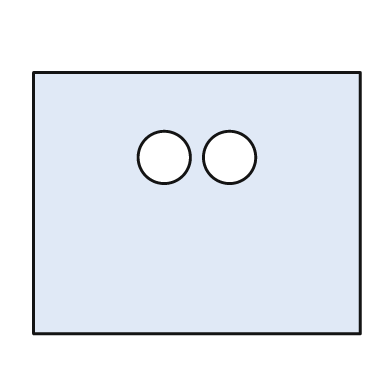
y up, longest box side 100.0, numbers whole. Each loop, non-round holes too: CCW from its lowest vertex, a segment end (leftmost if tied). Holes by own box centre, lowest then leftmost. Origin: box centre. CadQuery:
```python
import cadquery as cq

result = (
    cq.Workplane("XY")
    .moveTo(-50.0, -40.0)
    .lineTo(50.0, -40.0)
    .lineTo(50.0, 40.0)
    .lineTo(-50.0, 40.0)
    .close()
    .moveTo(-10.0, 14.0)
    .circle(8.0)
    .moveTo(10.0, 14.0)
    .circle(8.0)
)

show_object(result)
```